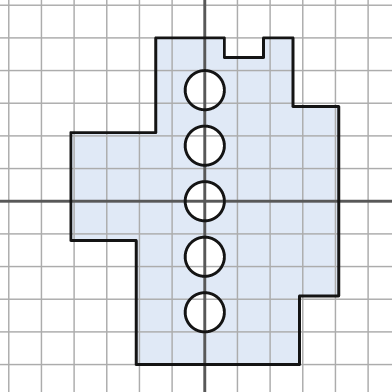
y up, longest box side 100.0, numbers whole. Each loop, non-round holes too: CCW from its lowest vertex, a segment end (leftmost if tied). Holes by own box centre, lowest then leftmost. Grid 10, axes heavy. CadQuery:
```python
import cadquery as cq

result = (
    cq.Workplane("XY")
    .moveTo(-21.0, -50.0)
    .lineTo(29.0, -50.0)
    .lineTo(29.0, -29.0)
    .lineTo(41.0, -29.0)
    .lineTo(41.0, 29.0)
    .lineTo(27.0, 29.0)
    .lineTo(27.0, 50.0)
    .lineTo(18.0, 50.0)
    .lineTo(18.0, 44.0)
    .lineTo(6.0, 44.0)
    .lineTo(6.0, 50.0)
    .lineTo(-15.0, 50.0)
    .lineTo(-15.0, 21.0)
    .lineTo(-41.0, 21.0)
    .lineTo(-41.0, -12.0)
    .lineTo(-21.0, -12.0)
    .close()
    .moveTo(0.0, -34.0)
    .circle(6.0)
    .moveTo(0.0, -17.0)
    .circle(6.0)
    .moveTo(0.0, 0.0)
    .circle(6.0)
    .moveTo(0.0, 17.0)
    .circle(6.0)
    .moveTo(0.0, 34.0)
    .circle(6.0)
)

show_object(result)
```